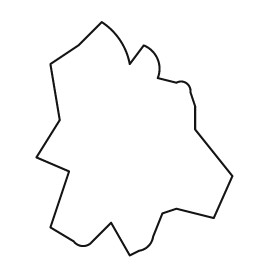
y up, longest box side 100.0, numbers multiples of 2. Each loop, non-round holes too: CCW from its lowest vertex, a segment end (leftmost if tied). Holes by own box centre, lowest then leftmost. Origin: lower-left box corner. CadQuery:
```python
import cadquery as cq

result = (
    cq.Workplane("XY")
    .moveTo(40.0, 0.0)
    .lineTo(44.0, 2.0)
    .threePointArc((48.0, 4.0), (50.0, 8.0))
    .lineTo(54.0, 18.0)
    .lineTo(60.0, 20.0)
    .lineTo(76.0, 16.0)
    .lineTo(84.0, 34.0)
    .lineTo(68.0, 54.0)
    .lineTo(68.0, 64.0)
    .lineTo(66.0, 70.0)
    .threePointArc((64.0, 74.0), (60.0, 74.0))
    .lineTo(52.0, 76.0)
    .threePointArc((52.0, 84.0), (46.0, 90.0))
    .lineTo(40.0, 82.0)
    .threePointArc((36.0, 92.0), (28.0, 100.0))
    .lineTo(18.0, 90.0)
    .lineTo(6.0, 82.0)
    .lineTo(10.0, 58.0)
    .lineTo(0.0, 42.0)
    .lineTo(14.0, 36.0)
    .lineTo(6.0, 12.0)
    .lineTo(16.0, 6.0)
    .threePointArc((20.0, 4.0), (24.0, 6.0))
    .lineTo(32.0, 14.0)
    .close()
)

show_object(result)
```